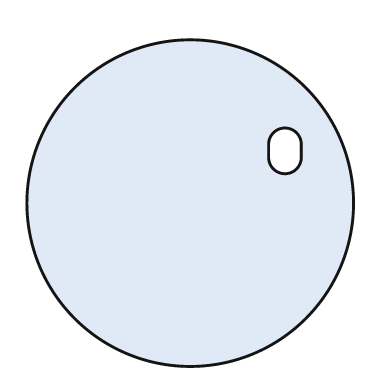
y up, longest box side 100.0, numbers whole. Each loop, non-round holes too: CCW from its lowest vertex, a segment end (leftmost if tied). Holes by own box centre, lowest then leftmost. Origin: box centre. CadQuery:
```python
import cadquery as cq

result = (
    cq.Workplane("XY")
    .moveTo(0.0, 0.0)
    .circle(50.0)
    .moveTo(24.0, 14.0)
    .threePointArc((29.0, 9.0), (34.0, 14.0))
    .lineTo(34.0, 18.0)
    .threePointArc((29.0, 23.0), (24.0, 18.0))
    .close()
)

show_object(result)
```